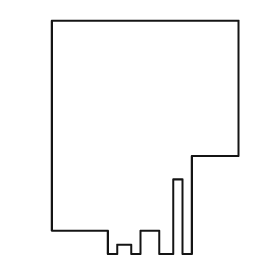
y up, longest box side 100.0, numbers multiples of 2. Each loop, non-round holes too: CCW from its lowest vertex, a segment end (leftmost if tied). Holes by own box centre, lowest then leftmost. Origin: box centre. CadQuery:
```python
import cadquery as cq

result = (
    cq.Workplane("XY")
    .moveTo(-16.0, -50.0)
    .lineTo(-12.0, -50.0)
    .lineTo(-12.0, -46.0)
    .lineTo(-6.0, -46.0)
    .lineTo(-6.0, -50.0)
    .lineTo(-2.0, -50.0)
    .lineTo(-2.0, -40.0)
    .lineTo(6.0, -40.0)
    .lineTo(6.0, -50.0)
    .lineTo(12.0, -50.0)
    .lineTo(12.0, -18.0)
    .lineTo(16.0, -18.0)
    .lineTo(16.0, -50.0)
    .lineTo(20.0, -50.0)
    .lineTo(20.0, -8.0)
    .lineTo(40.0, -8.0)
    .lineTo(40.0, 50.0)
    .lineTo(-40.0, 50.0)
    .lineTo(-40.0, -40.0)
    .lineTo(-16.0, -40.0)
    .close()
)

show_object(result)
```